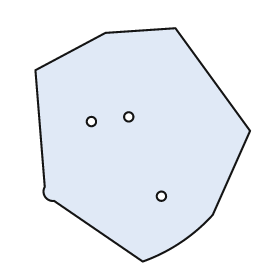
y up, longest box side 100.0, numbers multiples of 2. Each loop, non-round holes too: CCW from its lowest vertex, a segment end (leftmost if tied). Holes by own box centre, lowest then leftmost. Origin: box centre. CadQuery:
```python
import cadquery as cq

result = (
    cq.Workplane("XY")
    .moveTo(0.0, -50.0)
    .threePointArc((16.0, -42.0), (30.0, -30.0))
    .lineTo(46.0, 6.0)
    .lineTo(14.0, 50.0)
    .lineTo(-16.0, 48.0)
    .lineTo(-46.0, 32.0)
    .lineTo(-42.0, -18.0)
    .threePointArc((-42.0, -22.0), (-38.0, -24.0))
    .close()
    .moveTo(8.0, -22.0)
    .circle(2.0)
    .moveTo(-22.0, 10.0)
    .circle(2.0)
    .moveTo(-6.0, 12.0)
    .circle(2.0)
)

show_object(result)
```